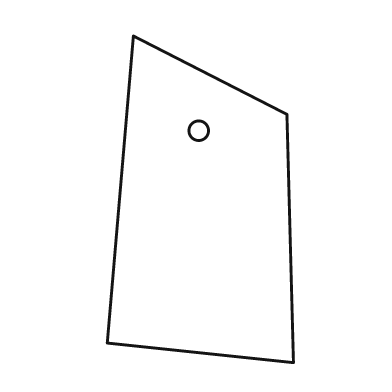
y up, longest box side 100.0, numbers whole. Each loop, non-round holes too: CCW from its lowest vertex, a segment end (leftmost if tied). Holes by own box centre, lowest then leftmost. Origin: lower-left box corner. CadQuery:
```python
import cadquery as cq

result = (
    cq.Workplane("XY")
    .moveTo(57.0, 0.0)
    .lineTo(55.0, 76.0)
    .lineTo(8.0, 100.0)
    .lineTo(0.0, 6.0)
    .close()
    .moveTo(28.0, 71.0)
    .circle(3.0)
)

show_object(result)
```